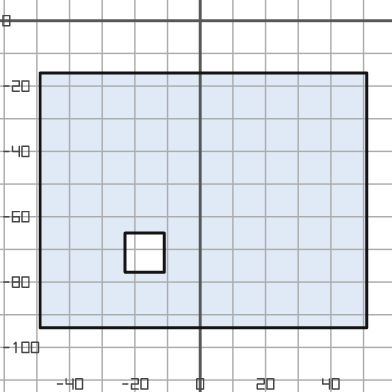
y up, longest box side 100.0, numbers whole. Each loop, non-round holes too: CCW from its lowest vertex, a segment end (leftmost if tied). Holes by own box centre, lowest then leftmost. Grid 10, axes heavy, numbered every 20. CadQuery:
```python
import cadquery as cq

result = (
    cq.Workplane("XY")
    .moveTo(-49.0, -94.0)
    .lineTo(51.0, -94.0)
    .lineTo(51.0, -16.0)
    .lineTo(-49.0, -16.0)
    .close()
    .moveTo(-23.0, -77.0)
    .lineTo(-11.0, -77.0)
    .lineTo(-11.0, -65.0)
    .lineTo(-23.0, -65.0)
    .close()
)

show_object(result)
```